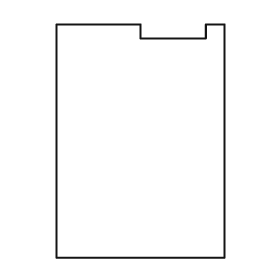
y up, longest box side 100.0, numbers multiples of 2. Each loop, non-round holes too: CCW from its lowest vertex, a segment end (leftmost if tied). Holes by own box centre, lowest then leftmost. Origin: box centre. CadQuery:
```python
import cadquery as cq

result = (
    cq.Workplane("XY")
    .moveTo(-36.0, -50.0)
    .lineTo(36.0, -50.0)
    .lineTo(36.0, 50.0)
    .lineTo(28.0, 50.0)
    .lineTo(28.0, 44.0)
    .lineTo(0.0, 44.0)
    .lineTo(0.0, 50.0)
    .lineTo(-36.0, 50.0)
    .close()
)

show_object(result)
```